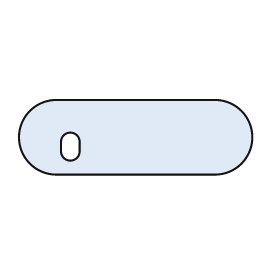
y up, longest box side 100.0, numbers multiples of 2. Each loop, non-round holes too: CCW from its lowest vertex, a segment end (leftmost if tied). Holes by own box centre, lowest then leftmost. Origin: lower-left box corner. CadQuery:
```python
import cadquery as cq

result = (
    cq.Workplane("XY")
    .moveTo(16.0, 0.0)
    .lineTo(84.0, 0.0)
    .threePointArc((100.0, 16.0), (84.0, 32.0))
    .lineTo(16.0, 32.0)
    .threePointArc((0.0, 16.0), (16.0, 0.0))
    .close()
    .moveTo(18.0, 10.0)
    .threePointArc((22.0, 6.0), (26.0, 10.0))
    .lineTo(26.0, 14.0)
    .threePointArc((22.0, 18.0), (18.0, 14.0))
    .close()
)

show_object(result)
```